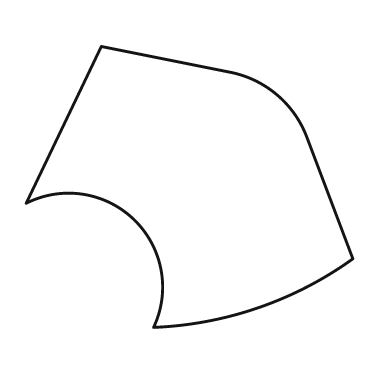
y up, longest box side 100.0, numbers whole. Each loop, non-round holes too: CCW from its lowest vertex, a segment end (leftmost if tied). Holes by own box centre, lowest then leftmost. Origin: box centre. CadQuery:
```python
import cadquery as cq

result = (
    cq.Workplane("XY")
    .moveTo(-11.0, -43.0)
    .threePointArc((21.0, -37.0), (50.0, -22.0))
    .lineTo(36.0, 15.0)
    .threePointArc((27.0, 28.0), (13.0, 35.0))
    .lineTo(-27.0, 43.0)
    .lineTo(-50.0, -5.0)
    .threePointArc((-17.0, -10.0), (-11.0, -43.0))
    .close()
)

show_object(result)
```